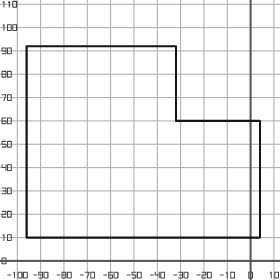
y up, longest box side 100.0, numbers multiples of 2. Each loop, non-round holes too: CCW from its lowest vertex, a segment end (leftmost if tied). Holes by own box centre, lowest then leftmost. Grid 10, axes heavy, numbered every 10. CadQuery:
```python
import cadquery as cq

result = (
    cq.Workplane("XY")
    .moveTo(-96.0, 10.0)
    .lineTo(4.0, 10.0)
    .lineTo(4.0, 60.0)
    .lineTo(-32.0, 60.0)
    .lineTo(-32.0, 92.0)
    .lineTo(-96.0, 92.0)
    .close()
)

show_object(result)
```